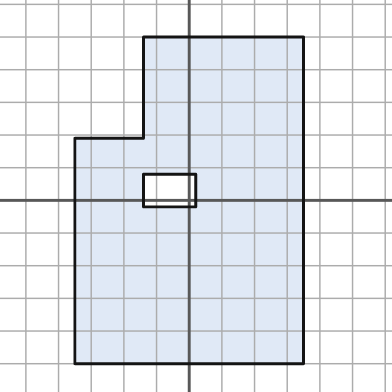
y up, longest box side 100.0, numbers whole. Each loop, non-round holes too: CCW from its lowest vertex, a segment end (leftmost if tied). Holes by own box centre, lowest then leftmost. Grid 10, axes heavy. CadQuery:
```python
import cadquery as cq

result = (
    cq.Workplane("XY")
    .moveTo(-35.0, -50.0)
    .lineTo(35.0, -50.0)
    .lineTo(35.0, 50.0)
    .lineTo(-14.0, 50.0)
    .lineTo(-14.0, 19.0)
    .lineTo(-35.0, 19.0)
    .close()
    .moveTo(-14.0, -2.0)
    .lineTo(2.0, -2.0)
    .lineTo(2.0, 8.0)
    .lineTo(-14.0, 8.0)
    .close()
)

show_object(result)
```